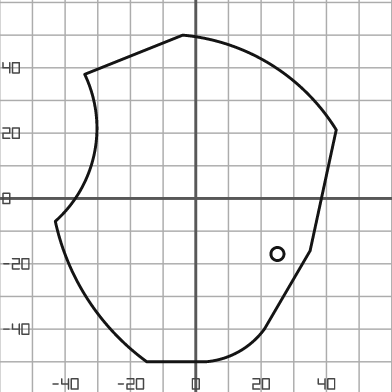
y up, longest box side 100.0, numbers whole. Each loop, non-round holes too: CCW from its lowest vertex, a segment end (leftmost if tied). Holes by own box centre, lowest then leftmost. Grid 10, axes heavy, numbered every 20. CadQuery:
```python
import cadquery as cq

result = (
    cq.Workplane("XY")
    .moveTo(-15.0, -50.0)
    .lineTo(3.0, -50.0)
    .threePointArc((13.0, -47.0), (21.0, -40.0))
    .lineTo(35.0, -16.0)
    .lineTo(43.0, 21.0)
    .threePointArc((23.0, 41.0), (-4.0, 50.0))
    .lineTo(-34.0, 38.0)
    .threePointArc((-31.0, 14.0), (-43.0, -7.0))
    .threePointArc((-33.0, -31.0), (-15.0, -50.0))
    .close()
    .moveTo(25.0, -17.0)
    .circle(2.0)
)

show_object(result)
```